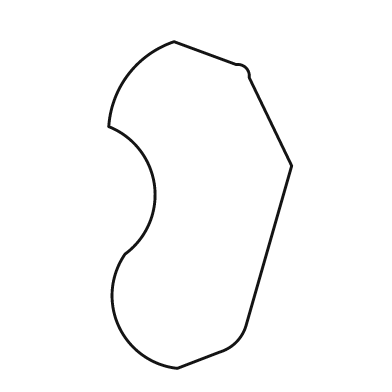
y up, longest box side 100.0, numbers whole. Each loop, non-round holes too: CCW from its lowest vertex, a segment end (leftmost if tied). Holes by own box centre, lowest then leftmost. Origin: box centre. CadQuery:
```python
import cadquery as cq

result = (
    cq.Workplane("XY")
    .moveTo(-7.0, -50.0)
    .lineTo(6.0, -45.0)
    .threePointArc((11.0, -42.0), (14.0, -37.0))
    .lineTo(28.0, 12.0)
    .lineTo(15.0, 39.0)
    .threePointArc((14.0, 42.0), (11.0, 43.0))
    .lineTo(-8.0, 50.0)
    .threePointArc((-22.0, 40.0), (-28.0, 24.0))
    .threePointArc((-14.0, 6.0), (-23.0, -15.0))
    .threePointArc((-25.0, -37.0), (-7.0, -50.0))
    .close()
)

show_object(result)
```